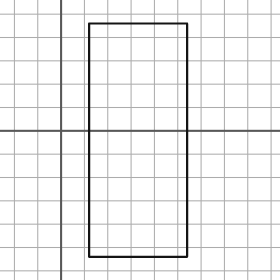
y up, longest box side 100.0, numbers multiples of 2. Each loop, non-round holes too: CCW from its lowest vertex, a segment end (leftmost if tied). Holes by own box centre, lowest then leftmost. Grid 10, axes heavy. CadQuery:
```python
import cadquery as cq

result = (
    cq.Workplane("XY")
    .moveTo(12.0, -54.0)
    .lineTo(54.0, -54.0)
    .lineTo(54.0, 46.0)
    .lineTo(12.0, 46.0)
    .close()
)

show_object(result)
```